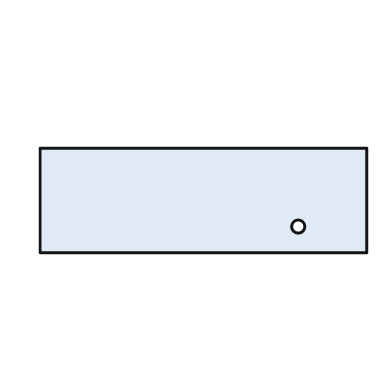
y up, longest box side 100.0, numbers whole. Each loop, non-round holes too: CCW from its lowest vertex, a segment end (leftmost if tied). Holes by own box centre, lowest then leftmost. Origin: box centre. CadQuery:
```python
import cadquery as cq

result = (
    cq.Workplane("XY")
    .moveTo(-50.0, -16.0)
    .lineTo(50.0, -16.0)
    .lineTo(50.0, 16.0)
    .lineTo(-50.0, 16.0)
    .close()
    .moveTo(29.0, -8.0)
    .circle(2.0)
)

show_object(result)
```